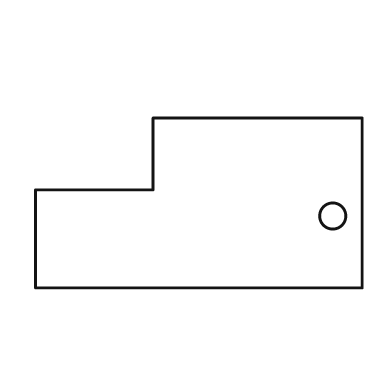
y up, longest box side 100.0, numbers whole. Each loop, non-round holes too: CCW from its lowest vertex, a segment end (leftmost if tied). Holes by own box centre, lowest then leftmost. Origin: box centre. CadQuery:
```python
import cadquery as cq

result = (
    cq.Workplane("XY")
    .moveTo(-50.0, -26.0)
    .lineTo(50.0, -26.0)
    .lineTo(50.0, 26.0)
    .lineTo(-14.0, 26.0)
    .lineTo(-14.0, 4.0)
    .lineTo(-50.0, 4.0)
    .close()
    .moveTo(41.0, -4.0)
    .circle(4.0)
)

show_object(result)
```